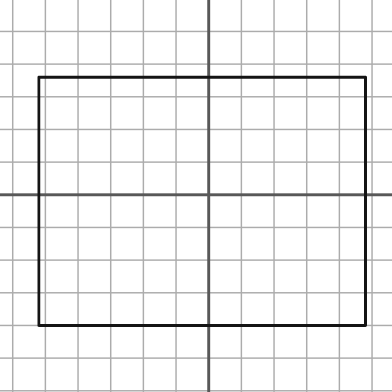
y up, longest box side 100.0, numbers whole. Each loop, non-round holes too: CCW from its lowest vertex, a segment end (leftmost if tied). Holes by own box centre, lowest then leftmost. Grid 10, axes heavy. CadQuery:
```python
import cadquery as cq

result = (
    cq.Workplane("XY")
    .moveTo(-52.0, -40.0)
    .lineTo(48.0, -40.0)
    .lineTo(48.0, 36.0)
    .lineTo(-52.0, 36.0)
    .close()
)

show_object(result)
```